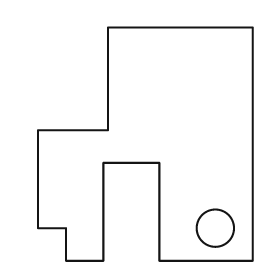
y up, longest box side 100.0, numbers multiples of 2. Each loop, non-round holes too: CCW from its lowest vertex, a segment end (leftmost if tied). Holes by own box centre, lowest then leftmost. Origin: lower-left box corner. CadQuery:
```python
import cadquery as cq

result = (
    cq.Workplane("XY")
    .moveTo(12.0, 0.0)
    .lineTo(28.0, 0.0)
    .lineTo(28.0, 42.0)
    .lineTo(52.0, 42.0)
    .lineTo(52.0, 0.0)
    .lineTo(92.0, 0.0)
    .lineTo(92.0, 100.0)
    .lineTo(30.0, 100.0)
    .lineTo(30.0, 56.0)
    .lineTo(0.0, 56.0)
    .lineTo(0.0, 14.0)
    .lineTo(12.0, 14.0)
    .close()
    .moveTo(76.0, 14.0)
    .circle(8.0)
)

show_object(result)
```